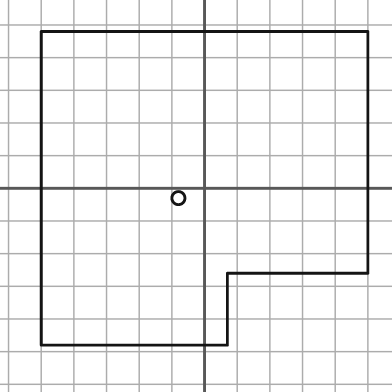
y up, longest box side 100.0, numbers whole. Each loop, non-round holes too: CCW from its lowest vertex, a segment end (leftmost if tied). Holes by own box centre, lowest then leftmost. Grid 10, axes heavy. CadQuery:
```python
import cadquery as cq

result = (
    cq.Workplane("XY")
    .moveTo(-50.0, -48.0)
    .lineTo(7.0, -48.0)
    .lineTo(7.0, -26.0)
    .lineTo(50.0, -26.0)
    .lineTo(50.0, 48.0)
    .lineTo(-50.0, 48.0)
    .close()
    .moveTo(-8.0, -3.0)
    .circle(2.0)
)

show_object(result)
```